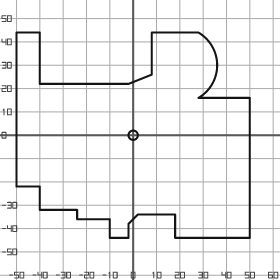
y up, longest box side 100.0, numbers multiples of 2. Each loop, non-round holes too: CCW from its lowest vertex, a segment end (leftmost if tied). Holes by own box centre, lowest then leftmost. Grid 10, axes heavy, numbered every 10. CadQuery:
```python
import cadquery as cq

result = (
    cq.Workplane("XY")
    .moveTo(-10.0, -44.0)
    .lineTo(-2.0, -44.0)
    .lineTo(-2.0, -38.0)
    .lineTo(2.0, -34.0)
    .lineTo(18.0, -34.0)
    .lineTo(18.0, -44.0)
    .lineTo(50.0, -44.0)
    .lineTo(50.0, 16.0)
    .lineTo(28.0, 16.0)
    .threePointArc((36.0, 30.0), (28.0, 44.0))
    .lineTo(8.0, 44.0)
    .lineTo(8.0, 26.0)
    .lineTo(-2.0, 22.0)
    .lineTo(-40.0, 22.0)
    .lineTo(-40.0, 44.0)
    .lineTo(-50.0, 44.0)
    .lineTo(-50.0, -22.0)
    .lineTo(-40.0, -22.0)
    .lineTo(-40.0, -32.0)
    .lineTo(-24.0, -32.0)
    .lineTo(-24.0, -36.0)
    .lineTo(-10.0, -36.0)
    .close()
    .moveTo(0.0, 0.0)
    .circle(2.0)
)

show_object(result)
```